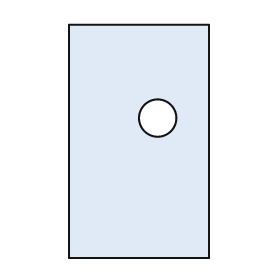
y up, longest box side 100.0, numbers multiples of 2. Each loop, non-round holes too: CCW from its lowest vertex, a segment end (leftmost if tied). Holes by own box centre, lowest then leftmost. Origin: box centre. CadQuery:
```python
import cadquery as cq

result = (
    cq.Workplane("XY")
    .moveTo(-30.0, -50.0)
    .lineTo(30.0, -50.0)
    .lineTo(30.0, 50.0)
    .lineTo(-30.0, 50.0)
    .close()
    .moveTo(8.0, 10.0)
    .circle(8.0)
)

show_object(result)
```